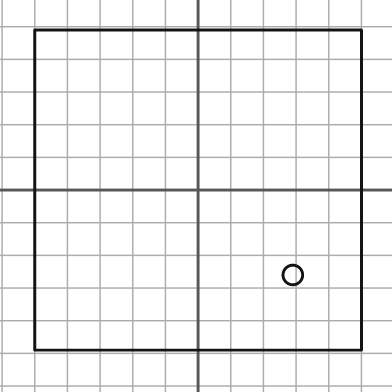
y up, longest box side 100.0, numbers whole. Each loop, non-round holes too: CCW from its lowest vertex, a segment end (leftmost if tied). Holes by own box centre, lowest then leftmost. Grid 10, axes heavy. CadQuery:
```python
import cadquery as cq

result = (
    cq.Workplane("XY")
    .moveTo(-50.0, -49.0)
    .lineTo(50.0, -49.0)
    .lineTo(50.0, 49.0)
    .lineTo(-50.0, 49.0)
    .close()
    .moveTo(29.0, -26.0)
    .circle(3.0)
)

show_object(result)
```